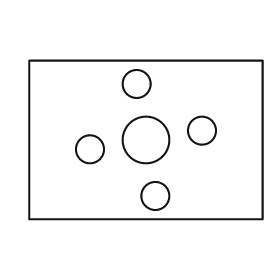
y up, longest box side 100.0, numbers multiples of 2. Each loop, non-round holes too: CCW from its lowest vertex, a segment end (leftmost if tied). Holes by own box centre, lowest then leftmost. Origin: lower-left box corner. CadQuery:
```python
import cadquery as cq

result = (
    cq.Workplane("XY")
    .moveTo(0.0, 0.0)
    .lineTo(100.0, 0.0)
    .lineTo(100.0, 68.0)
    .lineTo(0.0, 68.0)
    .close()
    .moveTo(54.0, 10.0)
    .circle(6.0)
    .moveTo(26.0, 30.0)
    .circle(6.0)
    .moveTo(50.0, 34.0)
    .circle(10.0)
    .moveTo(74.0, 38.0)
    .circle(6.0)
    .moveTo(46.0, 58.0)
    .circle(6.0)
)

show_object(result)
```